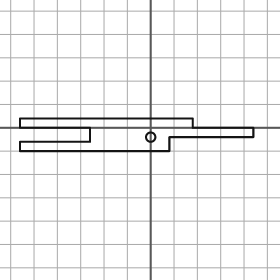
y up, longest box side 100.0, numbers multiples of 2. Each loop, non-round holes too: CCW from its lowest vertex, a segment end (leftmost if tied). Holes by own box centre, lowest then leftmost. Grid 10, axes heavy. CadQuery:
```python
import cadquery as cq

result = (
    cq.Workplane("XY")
    .moveTo(-56.0, -10.0)
    .lineTo(8.0, -10.0)
    .lineTo(8.0, -4.0)
    .lineTo(44.0, -4.0)
    .lineTo(44.0, 0.0)
    .lineTo(18.0, 0.0)
    .lineTo(18.0, 4.0)
    .lineTo(-56.0, 4.0)
    .lineTo(-56.0, 0.0)
    .lineTo(-26.0, 0.0)
    .lineTo(-26.0, -6.0)
    .lineTo(-56.0, -6.0)
    .close()
    .moveTo(0.0, -4.0)
    .circle(2.0)
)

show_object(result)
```